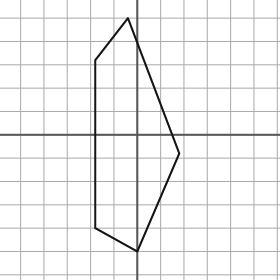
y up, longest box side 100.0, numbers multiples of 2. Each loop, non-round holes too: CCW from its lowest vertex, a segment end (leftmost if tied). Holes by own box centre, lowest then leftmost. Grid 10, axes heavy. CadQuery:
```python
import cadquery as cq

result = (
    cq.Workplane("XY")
    .moveTo(0.0, -50.0)
    .lineTo(18.0, -8.0)
    .lineTo(-4.0, 50.0)
    .lineTo(-18.0, 32.0)
    .lineTo(-18.0, -40.0)
    .close()
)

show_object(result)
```